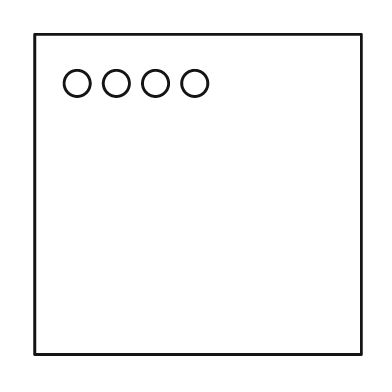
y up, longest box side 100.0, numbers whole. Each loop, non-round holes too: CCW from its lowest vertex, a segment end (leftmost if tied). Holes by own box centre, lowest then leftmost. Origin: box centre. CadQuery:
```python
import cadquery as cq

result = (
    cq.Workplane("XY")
    .moveTo(-50.0, -49.0)
    .lineTo(50.0, -49.0)
    .lineTo(50.0, 49.0)
    .lineTo(-50.0, 49.0)
    .close()
    .moveTo(-37.0, 34.0)
    .circle(4.0)
    .moveTo(-25.0, 34.0)
    .circle(4.0)
    .moveTo(-13.0, 34.0)
    .circle(4.0)
    .moveTo(-1.0, 34.0)
    .circle(4.0)
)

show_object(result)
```